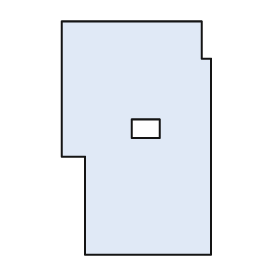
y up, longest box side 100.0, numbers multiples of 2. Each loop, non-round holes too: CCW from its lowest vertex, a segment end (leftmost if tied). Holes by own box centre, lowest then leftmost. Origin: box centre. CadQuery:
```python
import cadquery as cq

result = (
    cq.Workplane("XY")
    .moveTo(-22.0, -50.0)
    .lineTo(32.0, -50.0)
    .lineTo(32.0, 34.0)
    .lineTo(28.0, 34.0)
    .lineTo(28.0, 50.0)
    .lineTo(-32.0, 50.0)
    .lineTo(-32.0, -8.0)
    .lineTo(-22.0, -8.0)
    .close()
    .moveTo(-2.0, 0.0)
    .lineTo(10.0, 0.0)
    .lineTo(10.0, 8.0)
    .lineTo(-2.0, 8.0)
    .close()
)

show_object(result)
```